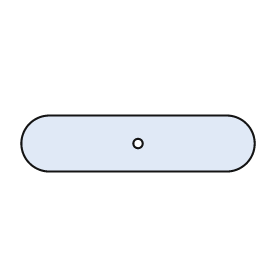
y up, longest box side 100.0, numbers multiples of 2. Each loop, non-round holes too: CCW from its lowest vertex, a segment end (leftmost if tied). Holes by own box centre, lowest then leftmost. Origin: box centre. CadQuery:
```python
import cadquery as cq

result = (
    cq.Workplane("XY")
    .moveTo(-38.0, -12.0)
    .lineTo(38.0, -12.0)
    .threePointArc((50.0, 0.0), (38.0, 12.0))
    .lineTo(-38.0, 12.0)
    .threePointArc((-50.0, 0.0), (-38.0, -12.0))
    .close()
    .moveTo(0.0, 0.0)
    .circle(2.0)
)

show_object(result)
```